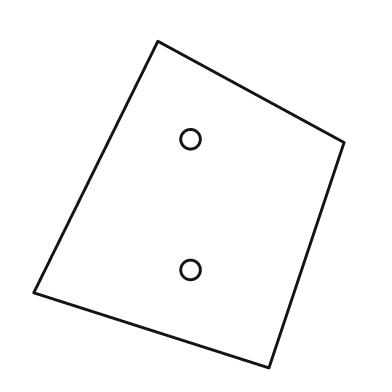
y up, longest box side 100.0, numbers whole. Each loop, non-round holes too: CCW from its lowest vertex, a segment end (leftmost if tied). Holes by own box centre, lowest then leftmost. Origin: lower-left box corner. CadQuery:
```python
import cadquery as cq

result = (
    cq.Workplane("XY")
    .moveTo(72.0, 0.0)
    .lineTo(95.0, 69.0)
    .lineTo(38.0, 100.0)
    .lineTo(0.0, 23.0)
    .close()
    .moveTo(48.0, 30.0)
    .circle(3.0)
    .moveTo(48.0, 70.0)
    .circle(3.0)
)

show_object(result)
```